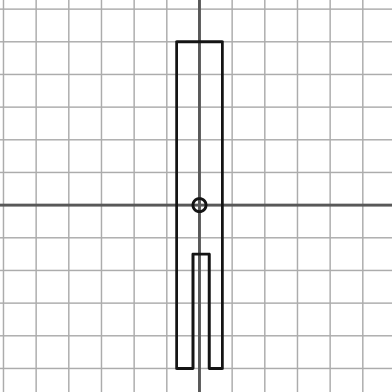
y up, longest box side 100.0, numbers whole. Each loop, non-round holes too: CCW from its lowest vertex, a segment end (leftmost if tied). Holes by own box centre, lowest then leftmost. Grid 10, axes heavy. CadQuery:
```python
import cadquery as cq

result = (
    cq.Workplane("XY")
    .moveTo(-7.0, -50.0)
    .lineTo(-2.0, -50.0)
    .lineTo(-2.0, -15.0)
    .lineTo(3.0, -15.0)
    .lineTo(3.0, -50.0)
    .lineTo(7.0, -50.0)
    .lineTo(7.0, 50.0)
    .lineTo(-7.0, 50.0)
    .close()
    .moveTo(0.0, 0.0)
    .circle(2.0)
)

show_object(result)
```